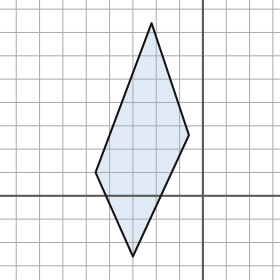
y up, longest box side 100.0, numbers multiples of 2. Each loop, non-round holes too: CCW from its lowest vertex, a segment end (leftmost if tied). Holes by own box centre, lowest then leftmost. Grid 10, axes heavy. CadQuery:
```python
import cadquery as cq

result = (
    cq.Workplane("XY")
    .moveTo(-30.0, -26.0)
    .lineTo(-6.0, 26.0)
    .lineTo(-22.0, 74.0)
    .lineTo(-46.0, 10.0)
    .close()
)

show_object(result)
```